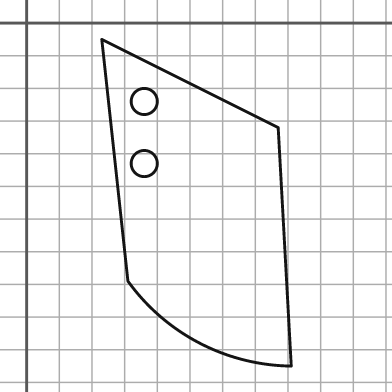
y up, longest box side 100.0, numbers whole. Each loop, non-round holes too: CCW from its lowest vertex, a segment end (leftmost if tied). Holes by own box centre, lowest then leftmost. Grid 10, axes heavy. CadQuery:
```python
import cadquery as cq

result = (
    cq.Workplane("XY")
    .moveTo(81.0, -105.0)
    .lineTo(77.0, -32.0)
    .lineTo(23.0, -5.0)
    .lineTo(31.0, -79.0)
    .threePointArc((53.0, -98.0), (81.0, -105.0))
    .close()
    .moveTo(36.0, -43.0)
    .circle(4.0)
    .moveTo(36.0, -24.0)
    .circle(4.0)
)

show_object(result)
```